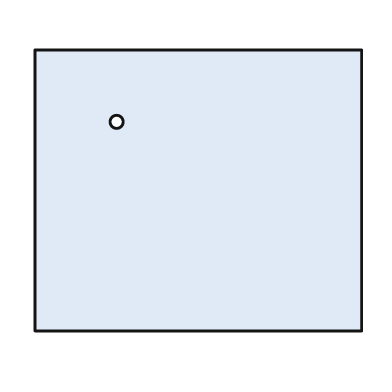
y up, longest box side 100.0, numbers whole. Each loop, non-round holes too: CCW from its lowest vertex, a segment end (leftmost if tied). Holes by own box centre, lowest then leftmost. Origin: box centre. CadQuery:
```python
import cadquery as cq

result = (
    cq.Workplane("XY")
    .moveTo(-50.0, -43.0)
    .lineTo(50.0, -43.0)
    .lineTo(50.0, 43.0)
    .lineTo(-50.0, 43.0)
    .close()
    .moveTo(-25.0, 21.0)
    .circle(2.0)
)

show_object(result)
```